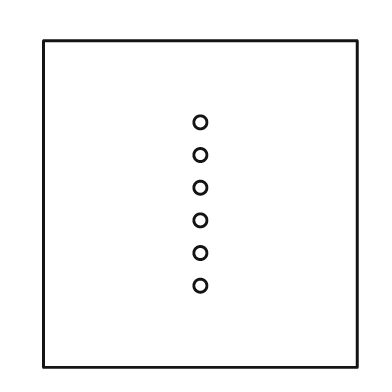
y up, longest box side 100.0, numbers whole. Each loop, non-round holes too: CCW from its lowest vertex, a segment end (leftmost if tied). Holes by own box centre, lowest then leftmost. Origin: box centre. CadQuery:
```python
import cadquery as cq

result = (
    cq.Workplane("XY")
    .moveTo(-48.0, -50.0)
    .lineTo(48.0, -50.0)
    .lineTo(48.0, 50.0)
    .lineTo(-48.0, 50.0)
    .close()
    .moveTo(0.0, -25.0)
    .circle(2.0)
    .moveTo(0.0, -15.0)
    .circle(2.0)
    .moveTo(0.0, -5.0)
    .circle(2.0)
    .moveTo(0.0, 5.0)
    .circle(2.0)
    .moveTo(0.0, 15.0)
    .circle(2.0)
    .moveTo(0.0, 25.0)
    .circle(2.0)
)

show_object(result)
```